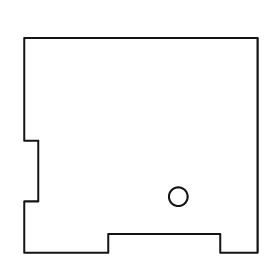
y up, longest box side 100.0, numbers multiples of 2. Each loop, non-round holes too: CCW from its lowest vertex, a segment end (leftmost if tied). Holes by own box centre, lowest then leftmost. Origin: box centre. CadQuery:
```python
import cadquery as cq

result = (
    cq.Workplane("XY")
    .moveTo(-50.0, -46.0)
    .lineTo(-14.0, -46.0)
    .lineTo(-14.0, -38.0)
    .lineTo(34.0, -38.0)
    .lineTo(34.0, -46.0)
    .lineTo(50.0, -46.0)
    .lineTo(50.0, 46.0)
    .lineTo(-50.0, 46.0)
    .lineTo(-50.0, 2.0)
    .lineTo(-44.0, 2.0)
    .lineTo(-44.0, -24.0)
    .lineTo(-50.0, -24.0)
    .close()
    .moveTo(16.0, -22.0)
    .circle(4.0)
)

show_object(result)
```